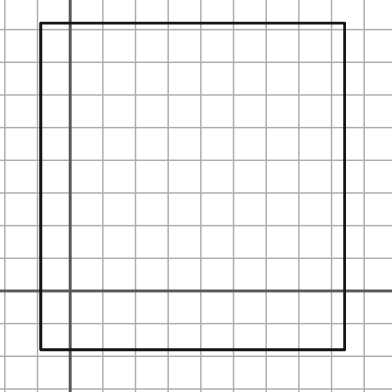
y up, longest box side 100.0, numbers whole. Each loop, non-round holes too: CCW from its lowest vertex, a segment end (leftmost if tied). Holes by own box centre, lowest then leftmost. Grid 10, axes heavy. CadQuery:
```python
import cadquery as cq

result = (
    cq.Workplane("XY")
    .moveTo(-9.0, -18.0)
    .lineTo(84.0, -18.0)
    .lineTo(84.0, 82.0)
    .lineTo(-9.0, 82.0)
    .close()
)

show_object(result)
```